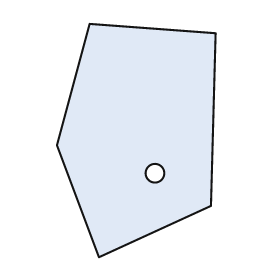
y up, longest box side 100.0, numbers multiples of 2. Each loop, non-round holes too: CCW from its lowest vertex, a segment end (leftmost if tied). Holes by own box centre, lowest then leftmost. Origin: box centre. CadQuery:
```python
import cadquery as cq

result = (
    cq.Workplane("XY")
    .moveTo(-16.0, -50.0)
    .lineTo(32.0, -28.0)
    .lineTo(34.0, 46.0)
    .lineTo(-20.0, 50.0)
    .lineTo(-34.0, -2.0)
    .close()
    .moveTo(8.0, -14.0)
    .circle(4.0)
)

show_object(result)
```